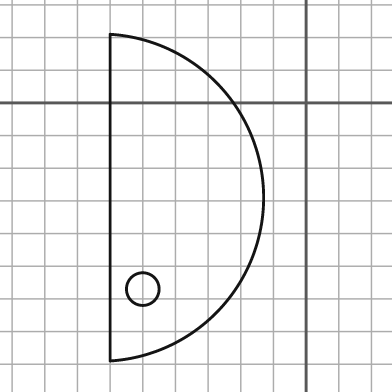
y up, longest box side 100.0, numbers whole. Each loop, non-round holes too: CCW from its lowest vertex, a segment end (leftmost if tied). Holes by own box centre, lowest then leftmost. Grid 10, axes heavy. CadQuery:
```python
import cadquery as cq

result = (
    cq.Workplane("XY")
    .moveTo(-60.0, -79.0)
    .threePointArc((-13.0, -29.0), (-60.0, 21.0))
    .close()
    .moveTo(-50.0, -57.0)
    .circle(5.0)
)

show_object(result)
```